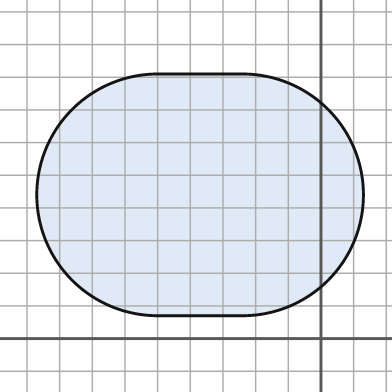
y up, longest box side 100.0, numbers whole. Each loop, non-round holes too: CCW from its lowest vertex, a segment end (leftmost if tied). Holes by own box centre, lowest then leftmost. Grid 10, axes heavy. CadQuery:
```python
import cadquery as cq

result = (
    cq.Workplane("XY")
    .moveTo(-50.0, 7.0)
    .lineTo(-24.0, 7.0)
    .threePointArc((13.0, 44.0), (-24.0, 81.0))
    .lineTo(-50.0, 81.0)
    .threePointArc((-87.0, 44.0), (-50.0, 7.0))
    .close()
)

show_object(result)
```